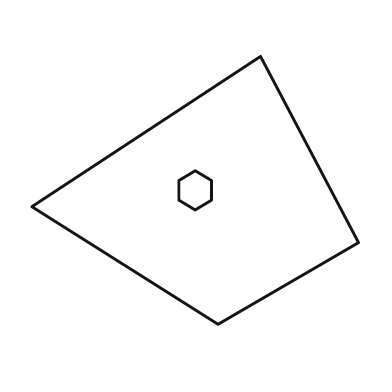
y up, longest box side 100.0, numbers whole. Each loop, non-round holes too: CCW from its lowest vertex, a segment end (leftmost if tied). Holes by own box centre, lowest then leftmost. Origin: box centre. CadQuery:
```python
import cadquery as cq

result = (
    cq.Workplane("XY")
    .moveTo(7.0, -41.0)
    .lineTo(50.0, -16.0)
    .lineTo(20.0, 41.0)
    .lineTo(-50.0, -5.0)
    .close()
    .moveTo(0.0, -6.0)
    .lineTo(5.0, -3.0)
    .lineTo(5.0, 3.0)
    .lineTo(0.0, 6.0)
    .lineTo(-5.0, 3.0)
    .lineTo(-5.0, -3.0)
    .close()
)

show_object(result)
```